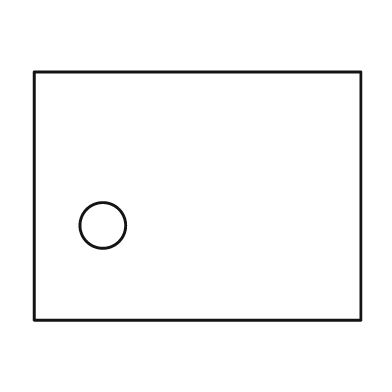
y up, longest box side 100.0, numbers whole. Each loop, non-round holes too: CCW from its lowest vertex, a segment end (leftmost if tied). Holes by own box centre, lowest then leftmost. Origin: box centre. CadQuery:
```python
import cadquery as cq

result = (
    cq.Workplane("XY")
    .moveTo(-50.0, -38.0)
    .lineTo(50.0, -38.0)
    .lineTo(50.0, 38.0)
    .lineTo(-50.0, 38.0)
    .close()
    .moveTo(-29.0, -9.0)
    .circle(7.0)
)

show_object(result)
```